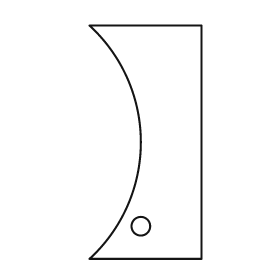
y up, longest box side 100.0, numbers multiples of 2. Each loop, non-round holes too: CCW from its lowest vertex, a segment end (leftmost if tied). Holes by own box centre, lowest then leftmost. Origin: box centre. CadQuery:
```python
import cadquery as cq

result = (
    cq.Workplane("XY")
    .moveTo(-24.0, -50.0)
    .lineTo(24.0, -50.0)
    .lineTo(24.0, 50.0)
    .lineTo(-24.0, 50.0)
    .threePointArc((-2.0, 0.0), (-24.0, -50.0))
    .close()
    .moveTo(-2.0, -36.0)
    .circle(4.0)
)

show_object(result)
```